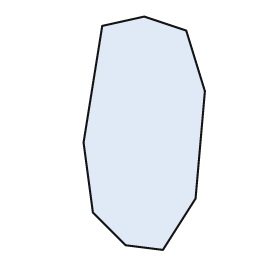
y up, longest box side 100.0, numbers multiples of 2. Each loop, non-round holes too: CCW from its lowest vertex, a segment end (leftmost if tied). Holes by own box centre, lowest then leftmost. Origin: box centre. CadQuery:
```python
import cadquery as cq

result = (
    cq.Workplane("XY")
    .moveTo(8.0, -50.0)
    .lineTo(22.0, -28.0)
    .lineTo(26.0, 18.0)
    .lineTo(18.0, 44.0)
    .lineTo(0.0, 50.0)
    .lineTo(-18.0, 46.0)
    .lineTo(-26.0, -4.0)
    .lineTo(-22.0, -34.0)
    .lineTo(-8.0, -48.0)
    .close()
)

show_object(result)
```